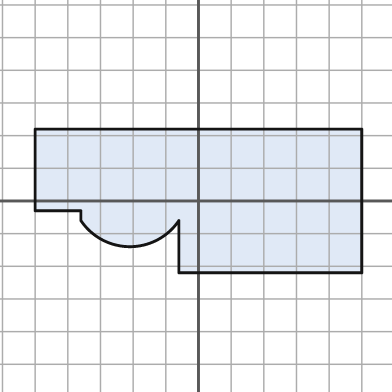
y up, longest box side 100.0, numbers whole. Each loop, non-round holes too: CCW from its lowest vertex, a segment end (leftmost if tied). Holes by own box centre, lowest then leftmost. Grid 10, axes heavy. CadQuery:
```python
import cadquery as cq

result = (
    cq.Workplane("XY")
    .moveTo(-6.0, -22.0)
    .lineTo(50.0, -22.0)
    .lineTo(50.0, 22.0)
    .lineTo(-50.0, 22.0)
    .lineTo(-50.0, -3.0)
    .lineTo(-36.0, -3.0)
    .lineTo(-36.0, -6.0)
    .threePointArc((-21.0, -14.0), (-6.0, -6.0))
    .close()
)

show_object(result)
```